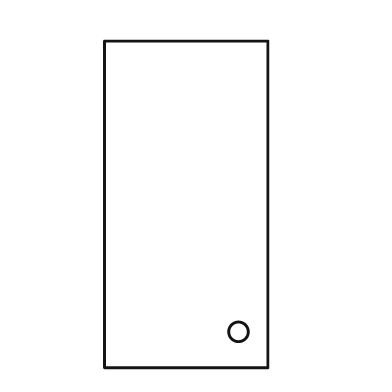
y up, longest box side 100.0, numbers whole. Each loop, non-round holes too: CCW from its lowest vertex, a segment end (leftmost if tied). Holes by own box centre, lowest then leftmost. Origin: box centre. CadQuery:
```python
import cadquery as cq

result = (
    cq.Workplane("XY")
    .moveTo(-25.0, -50.0)
    .lineTo(25.0, -50.0)
    .lineTo(25.0, 50.0)
    .lineTo(-25.0, 50.0)
    .close()
    .moveTo(16.0, -39.0)
    .circle(3.0)
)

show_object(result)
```